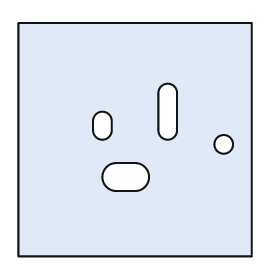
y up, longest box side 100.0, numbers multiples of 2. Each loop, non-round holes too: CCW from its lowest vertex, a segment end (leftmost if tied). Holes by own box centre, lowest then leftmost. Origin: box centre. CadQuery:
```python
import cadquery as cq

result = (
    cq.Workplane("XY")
    .moveTo(-50.0, -50.0)
    .lineTo(50.0, -50.0)
    .lineTo(50.0, 50.0)
    .lineTo(-50.0, 50.0)
    .close()
    .moveTo(-8.0, -22.0)
    .lineTo(0.0, -22.0)
    .threePointArc((6.0, -16.0), (0.0, -10.0))
    .lineTo(-8.0, -10.0)
    .threePointArc((-14.0, -16.0), (-8.0, -22.0))
    .close()
    .moveTo(38.0, -2.0)
    .circle(4.0)
    .moveTo(-18.0, 4.0)
    .threePointArc((-14.0, 0.0), (-10.0, 4.0))
    .lineTo(-10.0, 8.0)
    .threePointArc((-14.0, 12.0), (-18.0, 8.0))
    .close()
    .moveTo(10.0, 4.0)
    .threePointArc((14.0, 0.0), (18.0, 4.0))
    .lineTo(18.0, 20.0)
    .threePointArc((14.0, 24.0), (10.0, 20.0))
    .close()
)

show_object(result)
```